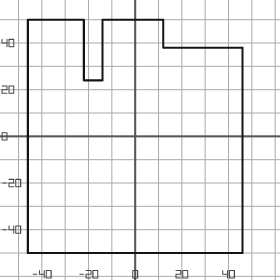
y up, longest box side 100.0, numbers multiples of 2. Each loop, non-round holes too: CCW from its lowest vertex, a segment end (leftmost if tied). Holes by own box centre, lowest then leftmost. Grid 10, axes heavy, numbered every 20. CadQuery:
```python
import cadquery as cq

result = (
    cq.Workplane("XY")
    .moveTo(-46.0, -50.0)
    .lineTo(46.0, -50.0)
    .lineTo(46.0, 38.0)
    .lineTo(12.0, 38.0)
    .lineTo(12.0, 50.0)
    .lineTo(-14.0, 50.0)
    .lineTo(-14.0, 24.0)
    .lineTo(-22.0, 24.0)
    .lineTo(-22.0, 50.0)
    .lineTo(-46.0, 50.0)
    .close()
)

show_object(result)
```